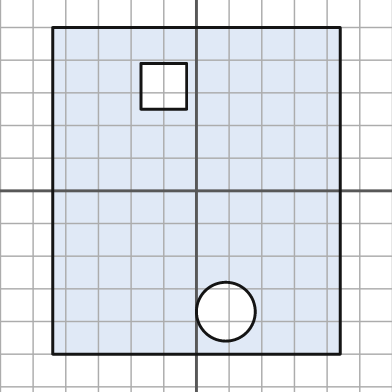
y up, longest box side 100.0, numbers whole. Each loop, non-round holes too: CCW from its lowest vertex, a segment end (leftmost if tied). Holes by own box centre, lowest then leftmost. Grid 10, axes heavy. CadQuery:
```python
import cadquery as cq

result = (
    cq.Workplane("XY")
    .moveTo(-44.0, -50.0)
    .lineTo(44.0, -50.0)
    .lineTo(44.0, 50.0)
    .lineTo(-44.0, 50.0)
    .close()
    .moveTo(9.0, -37.0)
    .circle(9.0)
    .moveTo(-17.0, 25.0)
    .lineTo(-3.0, 25.0)
    .lineTo(-3.0, 39.0)
    .lineTo(-17.0, 39.0)
    .close()
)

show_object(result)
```